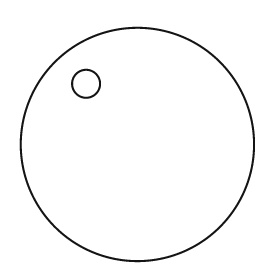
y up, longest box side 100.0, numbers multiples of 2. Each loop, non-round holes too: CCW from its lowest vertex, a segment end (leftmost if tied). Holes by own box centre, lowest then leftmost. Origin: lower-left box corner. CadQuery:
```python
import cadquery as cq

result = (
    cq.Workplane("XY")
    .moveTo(50.0, 50.0)
    .circle(50.0)
    .moveTo(28.0, 76.0)
    .circle(6.0)
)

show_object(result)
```